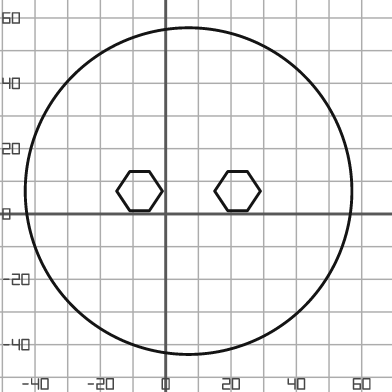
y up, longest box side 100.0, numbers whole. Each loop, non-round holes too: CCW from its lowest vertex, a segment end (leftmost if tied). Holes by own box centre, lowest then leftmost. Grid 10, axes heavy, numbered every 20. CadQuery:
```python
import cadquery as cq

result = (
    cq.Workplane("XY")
    .moveTo(7.0, 7.0)
    .circle(50.0)
    .moveTo(-11.0, 1.0)
    .lineTo(-5.0, 1.0)
    .lineTo(-1.0, 7.0)
    .lineTo(-5.0, 13.0)
    .lineTo(-11.0, 13.0)
    .lineTo(-15.0, 7.0)
    .close()
    .moveTo(19.0, 1.0)
    .lineTo(25.0, 1.0)
    .lineTo(29.0, 7.0)
    .lineTo(25.0, 13.0)
    .lineTo(19.0, 13.0)
    .lineTo(15.0, 7.0)
    .close()
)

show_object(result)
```